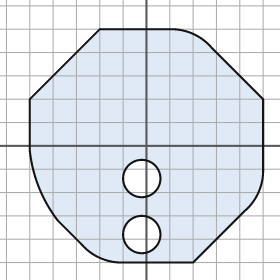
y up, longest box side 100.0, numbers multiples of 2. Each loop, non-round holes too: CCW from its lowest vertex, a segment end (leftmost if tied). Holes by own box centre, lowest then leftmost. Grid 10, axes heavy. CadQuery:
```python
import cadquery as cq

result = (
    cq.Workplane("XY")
    .moveTo(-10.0, -50.0)
    .lineTo(20.0, -50.0)
    .lineTo(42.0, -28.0)
    .threePointArc((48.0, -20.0), (50.0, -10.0))
    .lineTo(50.0, 20.0)
    .lineTo(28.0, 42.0)
    .threePointArc((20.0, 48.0), (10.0, 50.0))
    .lineTo(-20.0, 50.0)
    .lineTo(-50.0, 20.0)
    .lineTo(-50.0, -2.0)
    .threePointArc((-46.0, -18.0), (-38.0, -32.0))
    .lineTo(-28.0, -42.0)
    .threePointArc((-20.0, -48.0), (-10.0, -50.0))
    .close()
    .moveTo(-2.0, -38.0)
    .circle(8.0)
    .moveTo(-2.0, -14.0)
    .circle(8.0)
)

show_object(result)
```